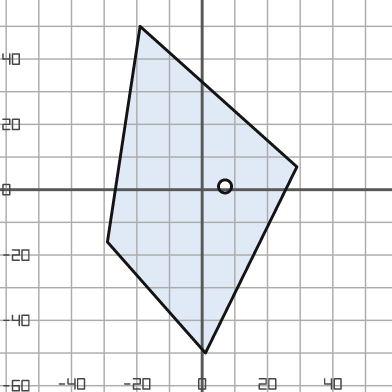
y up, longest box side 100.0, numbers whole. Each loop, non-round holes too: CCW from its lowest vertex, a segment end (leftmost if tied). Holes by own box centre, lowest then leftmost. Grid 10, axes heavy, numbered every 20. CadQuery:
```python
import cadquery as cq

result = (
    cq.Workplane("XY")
    .moveTo(1.0, -50.0)
    .lineTo(29.0, 7.0)
    .lineTo(-19.0, 50.0)
    .lineTo(-29.0, -16.0)
    .close()
    .moveTo(7.0, 1.0)
    .circle(2.0)
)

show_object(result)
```